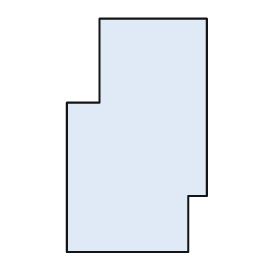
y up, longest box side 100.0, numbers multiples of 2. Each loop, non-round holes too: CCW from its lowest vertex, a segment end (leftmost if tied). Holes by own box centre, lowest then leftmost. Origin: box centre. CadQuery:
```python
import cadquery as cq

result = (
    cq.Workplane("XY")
    .moveTo(-30.0, -50.0)
    .lineTo(22.0, -50.0)
    .lineTo(22.0, -26.0)
    .lineTo(30.0, -26.0)
    .lineTo(30.0, 50.0)
    .lineTo(-16.0, 50.0)
    .lineTo(-16.0, 14.0)
    .lineTo(-30.0, 14.0)
    .close()
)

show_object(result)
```